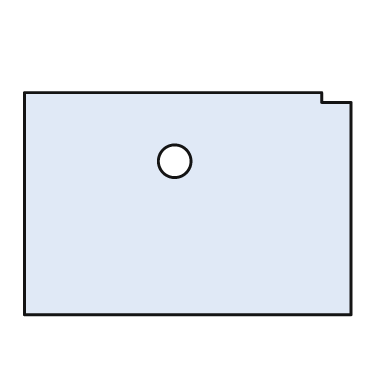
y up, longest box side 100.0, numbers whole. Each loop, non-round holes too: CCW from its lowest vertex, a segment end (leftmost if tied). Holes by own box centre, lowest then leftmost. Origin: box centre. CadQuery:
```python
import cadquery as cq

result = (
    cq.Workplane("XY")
    .moveTo(-50.0, -34.0)
    .lineTo(50.0, -34.0)
    .lineTo(50.0, 31.0)
    .lineTo(41.0, 31.0)
    .lineTo(41.0, 34.0)
    .lineTo(-50.0, 34.0)
    .close()
    .moveTo(-4.0, 13.0)
    .circle(5.0)
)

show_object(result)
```